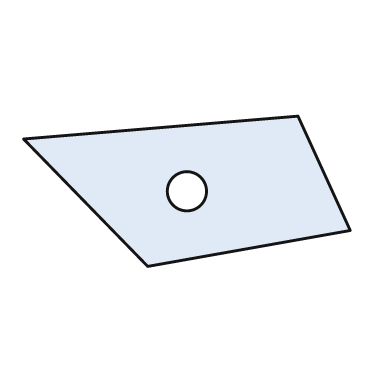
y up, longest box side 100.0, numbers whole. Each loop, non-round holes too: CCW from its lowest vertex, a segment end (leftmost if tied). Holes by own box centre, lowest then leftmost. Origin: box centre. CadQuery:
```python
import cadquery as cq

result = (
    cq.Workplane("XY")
    .moveTo(-12.0, -23.0)
    .lineTo(50.0, -12.0)
    .lineTo(34.0, 23.0)
    .lineTo(-50.0, 16.0)
    .close()
    .moveTo(0.0, 0.0)
    .circle(6.0)
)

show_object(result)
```